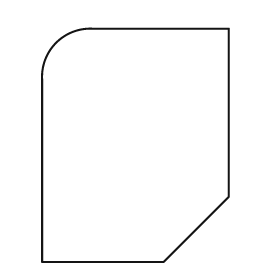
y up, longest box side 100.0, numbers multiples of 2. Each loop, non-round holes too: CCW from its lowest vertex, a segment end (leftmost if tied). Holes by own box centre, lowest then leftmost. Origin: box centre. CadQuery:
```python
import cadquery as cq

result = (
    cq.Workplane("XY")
    .moveTo(-40.0, -50.0)
    .lineTo(12.0, -50.0)
    .lineTo(40.0, -22.0)
    .lineTo(40.0, 50.0)
    .lineTo(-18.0, 50.0)
    .threePointArc((-34.0, 44.0), (-40.0, 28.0))
    .close()
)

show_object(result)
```